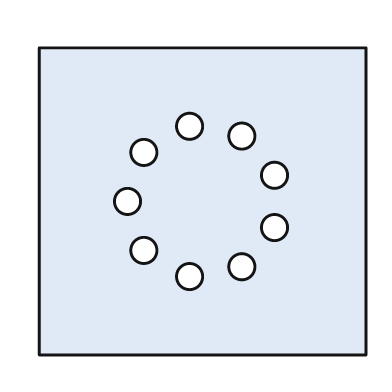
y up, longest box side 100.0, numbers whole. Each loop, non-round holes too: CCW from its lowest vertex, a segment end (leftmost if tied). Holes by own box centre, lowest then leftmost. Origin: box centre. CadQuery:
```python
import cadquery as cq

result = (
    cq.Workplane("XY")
    .moveTo(-50.0, -47.0)
    .lineTo(50.0, -47.0)
    .lineTo(50.0, 47.0)
    .lineTo(-50.0, 47.0)
    .close()
    .moveTo(-4.0, -23.0)
    .circle(4.0)
    .moveTo(12.0, -20.0)
    .circle(4.0)
    .moveTo(-18.0, -15.0)
    .circle(4.0)
    .moveTo(22.0, -8.0)
    .circle(4.0)
    .moveTo(-23.0, 0.0)
    .circle(4.0)
    .moveTo(22.0, 8.0)
    .circle(4.0)
    .moveTo(-18.0, 15.0)
    .circle(4.0)
    .moveTo(12.0, 20.0)
    .circle(4.0)
    .moveTo(-4.0, 23.0)
    .circle(4.0)
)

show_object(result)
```